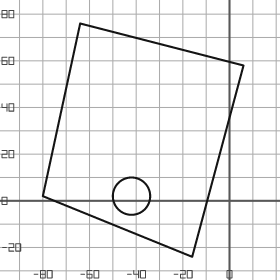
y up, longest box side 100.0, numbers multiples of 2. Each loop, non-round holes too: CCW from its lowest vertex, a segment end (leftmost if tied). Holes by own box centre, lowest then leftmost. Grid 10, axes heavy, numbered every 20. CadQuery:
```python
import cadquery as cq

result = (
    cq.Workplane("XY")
    .moveTo(-16.0, -24.0)
    .lineTo(6.0, 58.0)
    .lineTo(-64.0, 76.0)
    .lineTo(-80.0, 2.0)
    .close()
    .moveTo(-42.0, 2.0)
    .circle(8.0)
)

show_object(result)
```